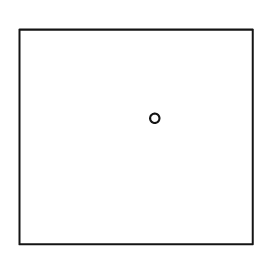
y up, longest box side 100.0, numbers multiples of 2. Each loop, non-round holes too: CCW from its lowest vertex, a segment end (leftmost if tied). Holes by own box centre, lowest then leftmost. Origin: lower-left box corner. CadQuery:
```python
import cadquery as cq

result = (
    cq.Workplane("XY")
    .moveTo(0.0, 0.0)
    .lineTo(100.0, 0.0)
    .lineTo(100.0, 92.0)
    .lineTo(0.0, 92.0)
    .close()
    .moveTo(58.0, 54.0)
    .circle(2.0)
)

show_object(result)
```